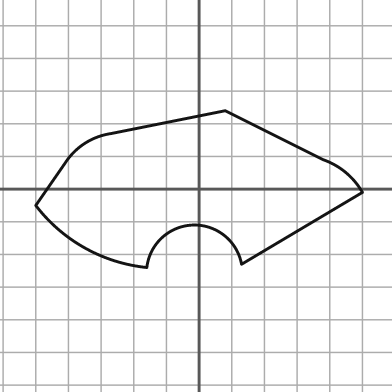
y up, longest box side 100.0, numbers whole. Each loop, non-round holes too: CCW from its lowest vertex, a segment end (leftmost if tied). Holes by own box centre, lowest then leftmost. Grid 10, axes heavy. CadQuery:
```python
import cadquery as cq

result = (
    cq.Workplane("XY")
    .moveTo(-16.0, -24.0)
    .threePointArc((-2.0, -11.0), (13.0, -23.0))
    .lineTo(50.0, -1.0)
    .threePointArc((45.0, 5.0), (38.0, 9.0))
    .lineTo(8.0, 24.0)
    .lineTo(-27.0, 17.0)
    .threePointArc((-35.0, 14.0), (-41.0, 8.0))
    .lineTo(-50.0, -5.0)
    .threePointArc((-35.0, -18.0), (-16.0, -24.0))
    .close()
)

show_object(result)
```